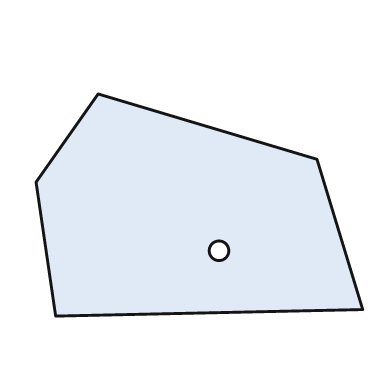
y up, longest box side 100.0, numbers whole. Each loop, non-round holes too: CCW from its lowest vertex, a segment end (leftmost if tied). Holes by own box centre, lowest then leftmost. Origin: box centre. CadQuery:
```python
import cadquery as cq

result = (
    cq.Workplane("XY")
    .moveTo(-44.0, -34.0)
    .lineTo(50.0, -32.0)
    .lineTo(36.0, 14.0)
    .lineTo(-31.0, 34.0)
    .lineTo(-50.0, 7.0)
    .close()
    .moveTo(6.0, -14.0)
    .circle(3.0)
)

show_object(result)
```